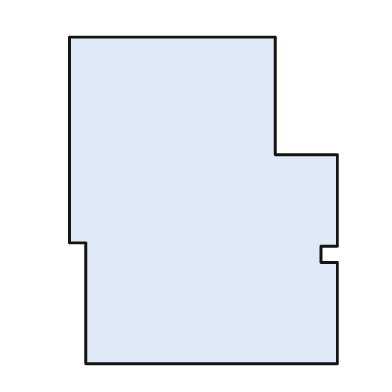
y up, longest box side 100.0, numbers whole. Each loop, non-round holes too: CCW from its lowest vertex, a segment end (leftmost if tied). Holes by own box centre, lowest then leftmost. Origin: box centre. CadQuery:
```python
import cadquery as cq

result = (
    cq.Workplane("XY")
    .moveTo(-36.0, -50.0)
    .lineTo(41.0, -50.0)
    .lineTo(41.0, -19.0)
    .lineTo(36.0, -19.0)
    .lineTo(36.0, -14.0)
    .lineTo(41.0, -14.0)
    .lineTo(41.0, 14.0)
    .lineTo(22.0, 14.0)
    .lineTo(22.0, 50.0)
    .lineTo(-41.0, 50.0)
    .lineTo(-41.0, -13.0)
    .lineTo(-36.0, -13.0)
    .close()
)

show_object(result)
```